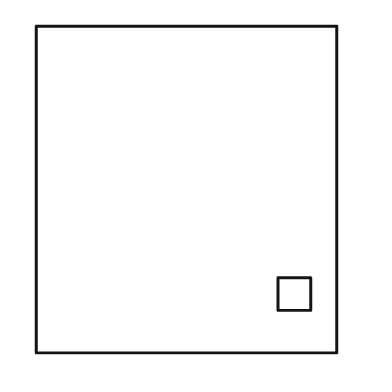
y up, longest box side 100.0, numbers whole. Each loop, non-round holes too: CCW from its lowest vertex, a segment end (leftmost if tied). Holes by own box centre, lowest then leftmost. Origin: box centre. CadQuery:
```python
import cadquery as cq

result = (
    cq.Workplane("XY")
    .moveTo(-46.0, -50.0)
    .lineTo(46.0, -50.0)
    .lineTo(46.0, 50.0)
    .lineTo(-46.0, 50.0)
    .close()
    .moveTo(28.0, -37.0)
    .lineTo(38.0, -37.0)
    .lineTo(38.0, -27.0)
    .lineTo(28.0, -27.0)
    .close()
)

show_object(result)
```